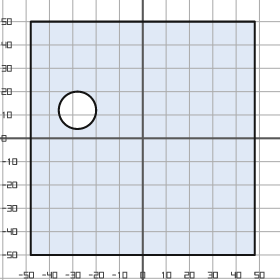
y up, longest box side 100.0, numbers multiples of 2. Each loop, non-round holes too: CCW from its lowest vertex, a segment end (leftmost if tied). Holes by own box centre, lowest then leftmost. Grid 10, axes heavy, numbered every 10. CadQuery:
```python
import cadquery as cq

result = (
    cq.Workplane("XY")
    .moveTo(-48.0, -50.0)
    .lineTo(48.0, -50.0)
    .lineTo(48.0, 50.0)
    .lineTo(-48.0, 50.0)
    .close()
    .moveTo(-28.0, 12.0)
    .circle(8.0)
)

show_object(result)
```